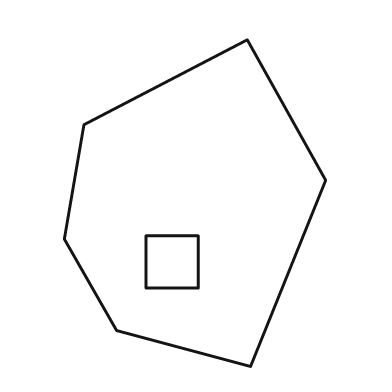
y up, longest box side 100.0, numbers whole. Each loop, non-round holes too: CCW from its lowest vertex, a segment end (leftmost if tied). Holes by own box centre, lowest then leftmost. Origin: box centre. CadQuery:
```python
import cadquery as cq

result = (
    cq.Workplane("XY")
    .moveTo(17.0, -50.0)
    .lineTo(40.0, 7.0)
    .lineTo(16.0, 50.0)
    .lineTo(-34.0, 24.0)
    .lineTo(-40.0, -11.0)
    .lineTo(-24.0, -39.0)
    .close()
    .moveTo(-15.0, -26.0)
    .lineTo(1.0, -26.0)
    .lineTo(1.0, -10.0)
    .lineTo(-15.0, -10.0)
    .close()
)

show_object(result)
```